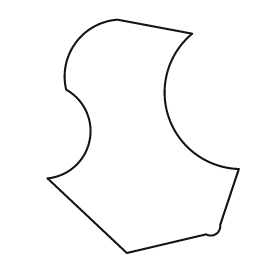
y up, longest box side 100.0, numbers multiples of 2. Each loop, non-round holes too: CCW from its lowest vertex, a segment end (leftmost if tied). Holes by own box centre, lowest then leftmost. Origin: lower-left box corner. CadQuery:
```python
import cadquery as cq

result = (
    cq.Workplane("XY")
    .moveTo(34.0, 0.0)
    .lineTo(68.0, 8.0)
    .threePointArc((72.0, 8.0), (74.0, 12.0))
    .lineTo(82.0, 36.0)
    .threePointArc((52.0, 58.0), (62.0, 94.0))
    .lineTo(30.0, 100.0)
    .threePointArc((12.0, 90.0), (8.0, 70.0))
    .threePointArc((18.0, 48.0), (0.0, 32.0))
    .close()
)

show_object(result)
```